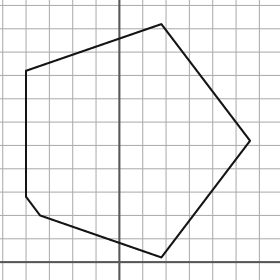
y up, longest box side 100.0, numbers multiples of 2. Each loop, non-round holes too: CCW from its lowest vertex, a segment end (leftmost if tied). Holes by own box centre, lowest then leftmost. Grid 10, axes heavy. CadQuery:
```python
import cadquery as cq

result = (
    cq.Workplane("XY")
    .moveTo(18.0, 2.0)
    .lineTo(56.0, 52.0)
    .lineTo(18.0, 102.0)
    .lineTo(-40.0, 82.0)
    .lineTo(-40.0, 28.0)
    .lineTo(-34.0, 20.0)
    .close()
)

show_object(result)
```